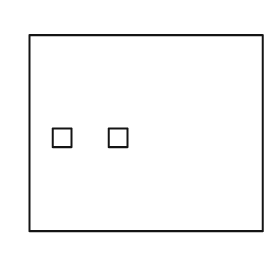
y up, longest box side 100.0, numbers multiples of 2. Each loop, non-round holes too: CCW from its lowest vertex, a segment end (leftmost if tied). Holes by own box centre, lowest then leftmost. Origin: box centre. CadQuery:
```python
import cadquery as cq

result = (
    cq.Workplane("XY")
    .moveTo(-50.0, -42.0)
    .lineTo(50.0, -42.0)
    .lineTo(50.0, 42.0)
    .lineTo(-50.0, 42.0)
    .close()
    .moveTo(-40.0, -6.0)
    .lineTo(-32.0, -6.0)
    .lineTo(-32.0, 2.0)
    .lineTo(-40.0, 2.0)
    .close()
    .moveTo(-16.0, -6.0)
    .lineTo(-8.0, -6.0)
    .lineTo(-8.0, 2.0)
    .lineTo(-16.0, 2.0)
    .close()
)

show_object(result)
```